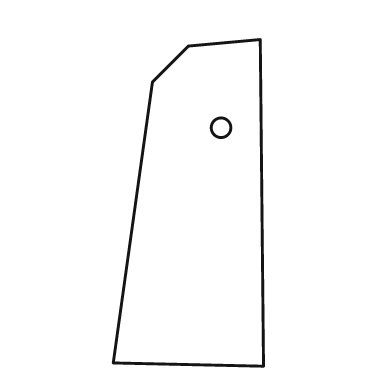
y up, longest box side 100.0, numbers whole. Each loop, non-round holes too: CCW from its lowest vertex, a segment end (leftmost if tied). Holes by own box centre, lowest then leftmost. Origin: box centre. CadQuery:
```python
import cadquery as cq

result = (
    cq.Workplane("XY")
    .moveTo(23.0, -50.0)
    .lineTo(22.0, 50.0)
    .lineTo(0.0, 48.0)
    .lineTo(-11.0, 37.0)
    .lineTo(-23.0, -49.0)
    .close()
    .moveTo(10.0, 23.0)
    .circle(3.0)
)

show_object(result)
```